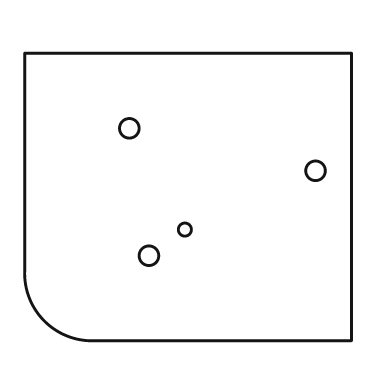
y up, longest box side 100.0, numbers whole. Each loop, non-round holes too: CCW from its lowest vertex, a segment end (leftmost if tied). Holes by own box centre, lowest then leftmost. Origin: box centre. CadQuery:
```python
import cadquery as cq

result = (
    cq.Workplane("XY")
    .moveTo(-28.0, -44.0)
    .lineTo(50.0, -44.0)
    .lineTo(50.0, 44.0)
    .lineTo(-50.0, 44.0)
    .lineTo(-50.0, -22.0)
    .threePointArc((-44.0, -38.0), (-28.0, -44.0))
    .close()
    .moveTo(-12.0, -18.0)
    .circle(3.0)
    .moveTo(-1.0, -10.0)
    .circle(2.0)
    .moveTo(39.0, 8.0)
    .circle(3.0)
    .moveTo(-18.0, 21.0)
    .circle(3.0)
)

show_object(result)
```